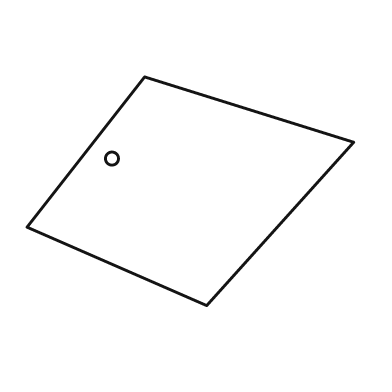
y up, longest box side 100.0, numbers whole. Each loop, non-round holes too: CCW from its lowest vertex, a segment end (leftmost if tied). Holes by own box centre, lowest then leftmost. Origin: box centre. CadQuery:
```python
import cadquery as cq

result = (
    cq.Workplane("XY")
    .moveTo(5.0, -35.0)
    .lineTo(50.0, 15.0)
    .lineTo(-14.0, 35.0)
    .lineTo(-50.0, -11.0)
    .close()
    .moveTo(-24.0, 10.0)
    .circle(2.0)
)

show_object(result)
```